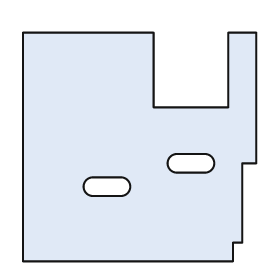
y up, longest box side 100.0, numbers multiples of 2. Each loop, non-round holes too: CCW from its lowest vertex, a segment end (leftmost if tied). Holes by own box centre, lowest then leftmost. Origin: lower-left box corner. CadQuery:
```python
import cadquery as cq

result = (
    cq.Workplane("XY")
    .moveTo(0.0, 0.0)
    .lineTo(90.0, 0.0)
    .lineTo(90.0, 8.0)
    .lineTo(94.0, 8.0)
    .lineTo(94.0, 42.0)
    .lineTo(100.0, 42.0)
    .lineTo(100.0, 98.0)
    .lineTo(88.0, 98.0)
    .lineTo(88.0, 66.0)
    .lineTo(56.0, 66.0)
    .lineTo(56.0, 98.0)
    .lineTo(0.0, 98.0)
    .close()
    .moveTo(30.0, 28.0)
    .lineTo(42.0, 28.0)
    .threePointArc((46.0, 32.0), (42.0, 36.0))
    .lineTo(30.0, 36.0)
    .threePointArc((26.0, 32.0), (30.0, 28.0))
    .close()
    .moveTo(66.0, 38.0)
    .lineTo(78.0, 38.0)
    .threePointArc((82.0, 42.0), (78.0, 46.0))
    .lineTo(66.0, 46.0)
    .threePointArc((62.0, 42.0), (66.0, 38.0))
    .close()
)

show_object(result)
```